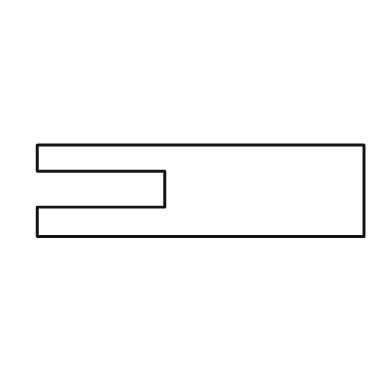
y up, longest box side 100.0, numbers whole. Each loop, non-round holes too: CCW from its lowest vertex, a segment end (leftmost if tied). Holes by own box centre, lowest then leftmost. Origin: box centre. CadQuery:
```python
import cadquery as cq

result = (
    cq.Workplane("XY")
    .moveTo(-50.0, -14.0)
    .lineTo(50.0, -14.0)
    .lineTo(50.0, 14.0)
    .lineTo(-50.0, 14.0)
    .lineTo(-50.0, 6.0)
    .lineTo(-11.0, 6.0)
    .lineTo(-11.0, -5.0)
    .lineTo(-50.0, -5.0)
    .close()
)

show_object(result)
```